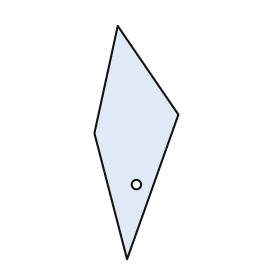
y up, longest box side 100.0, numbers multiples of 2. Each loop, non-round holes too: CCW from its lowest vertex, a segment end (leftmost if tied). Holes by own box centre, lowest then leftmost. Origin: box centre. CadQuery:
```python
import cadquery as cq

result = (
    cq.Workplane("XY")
    .moveTo(-4.0, -50.0)
    .lineTo(18.0, 12.0)
    .lineTo(-8.0, 50.0)
    .lineTo(-18.0, 4.0)
    .close()
    .moveTo(0.0, -18.0)
    .circle(2.0)
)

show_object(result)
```